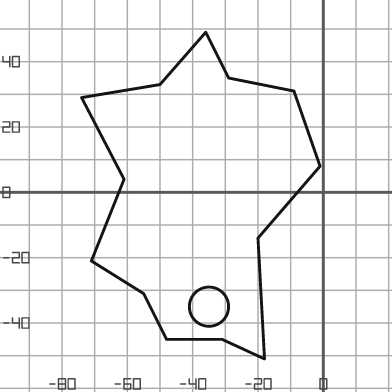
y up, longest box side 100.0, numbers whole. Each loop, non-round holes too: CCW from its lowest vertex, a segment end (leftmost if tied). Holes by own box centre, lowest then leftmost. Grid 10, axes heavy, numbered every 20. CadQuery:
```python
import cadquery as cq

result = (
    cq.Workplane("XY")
    .moveTo(-18.0, -51.0)
    .lineTo(-20.0, -14.0)
    .lineTo(-1.0, 8.0)
    .lineTo(-9.0, 31.0)
    .lineTo(-29.0, 35.0)
    .lineTo(-36.0, 49.0)
    .lineTo(-50.0, 33.0)
    .lineTo(-74.0, 29.0)
    .lineTo(-61.0, 4.0)
    .lineTo(-71.0, -21.0)
    .lineTo(-55.0, -31.0)
    .lineTo(-48.0, -45.0)
    .lineTo(-31.0, -45.0)
    .close()
    .moveTo(-35.0, -35.0)
    .circle(6.0)
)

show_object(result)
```